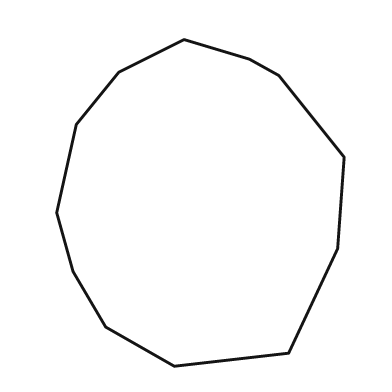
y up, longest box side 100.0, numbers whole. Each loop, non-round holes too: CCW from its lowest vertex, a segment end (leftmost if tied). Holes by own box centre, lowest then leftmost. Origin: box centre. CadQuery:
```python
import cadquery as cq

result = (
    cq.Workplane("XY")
    .moveTo(-8.0, -50.0)
    .lineTo(27.0, -46.0)
    .lineTo(42.0, -14.0)
    .lineTo(44.0, 14.0)
    .lineTo(24.0, 39.0)
    .lineTo(15.0, 44.0)
    .lineTo(-5.0, 50.0)
    .lineTo(-25.0, 40.0)
    .lineTo(-38.0, 24.0)
    .lineTo(-44.0, -3.0)
    .lineTo(-39.0, -21.0)
    .lineTo(-29.0, -38.0)
    .close()
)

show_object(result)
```